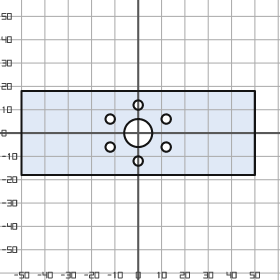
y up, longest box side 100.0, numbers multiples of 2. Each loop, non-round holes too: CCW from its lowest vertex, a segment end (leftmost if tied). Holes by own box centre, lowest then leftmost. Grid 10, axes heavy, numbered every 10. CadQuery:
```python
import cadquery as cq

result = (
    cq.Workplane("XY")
    .moveTo(-50.0, -18.0)
    .lineTo(50.0, -18.0)
    .lineTo(50.0, 18.0)
    .lineTo(-50.0, 18.0)
    .close()
    .moveTo(0.0, -12.0)
    .circle(2.0)
    .moveTo(-12.0, -6.0)
    .circle(2.0)
    .moveTo(12.0, -6.0)
    .circle(2.0)
    .moveTo(0.0, 0.0)
    .circle(6.0)
    .moveTo(-12.0, 6.0)
    .circle(2.0)
    .moveTo(12.0, 6.0)
    .circle(2.0)
    .moveTo(0.0, 12.0)
    .circle(2.0)
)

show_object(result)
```